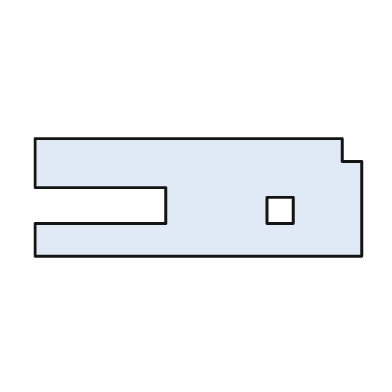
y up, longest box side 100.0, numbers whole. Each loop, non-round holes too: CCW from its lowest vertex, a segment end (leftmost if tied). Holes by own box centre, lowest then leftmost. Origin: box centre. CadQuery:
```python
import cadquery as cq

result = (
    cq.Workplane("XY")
    .moveTo(-50.0, -18.0)
    .lineTo(50.0, -18.0)
    .lineTo(50.0, 11.0)
    .lineTo(44.0, 11.0)
    .lineTo(44.0, 18.0)
    .lineTo(-50.0, 18.0)
    .lineTo(-50.0, 3.0)
    .lineTo(-10.0, 3.0)
    .lineTo(-10.0, -8.0)
    .lineTo(-50.0, -8.0)
    .close()
    .moveTo(21.0, -8.0)
    .lineTo(29.0, -8.0)
    .lineTo(29.0, 0.0)
    .lineTo(21.0, 0.0)
    .close()
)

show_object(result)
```